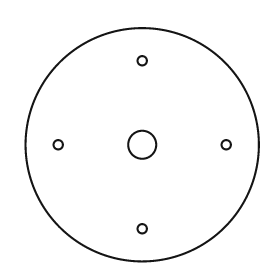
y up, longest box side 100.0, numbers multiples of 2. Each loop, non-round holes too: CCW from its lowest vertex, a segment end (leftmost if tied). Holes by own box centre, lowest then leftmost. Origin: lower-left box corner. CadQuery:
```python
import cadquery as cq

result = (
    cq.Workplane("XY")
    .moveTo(50.0, 50.0)
    .circle(50.0)
    .moveTo(50.0, 14.0)
    .circle(2.0)
    .moveTo(14.0, 50.0)
    .circle(2.0)
    .moveTo(50.0, 50.0)
    .circle(6.0)
    .moveTo(86.0, 50.0)
    .circle(2.0)
    .moveTo(50.0, 86.0)
    .circle(2.0)
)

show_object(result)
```